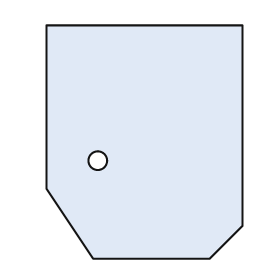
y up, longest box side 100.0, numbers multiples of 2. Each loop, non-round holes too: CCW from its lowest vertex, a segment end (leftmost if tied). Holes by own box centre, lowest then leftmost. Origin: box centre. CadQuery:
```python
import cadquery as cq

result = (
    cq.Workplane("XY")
    .moveTo(-22.0, -50.0)
    .lineTo(28.0, -50.0)
    .lineTo(42.0, -36.0)
    .lineTo(42.0, 50.0)
    .lineTo(-42.0, 50.0)
    .lineTo(-42.0, -20.0)
    .close()
    .moveTo(-20.0, -8.0)
    .circle(4.0)
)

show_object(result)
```